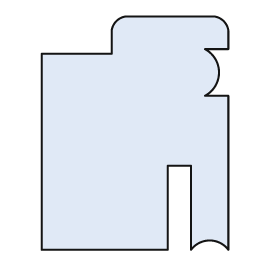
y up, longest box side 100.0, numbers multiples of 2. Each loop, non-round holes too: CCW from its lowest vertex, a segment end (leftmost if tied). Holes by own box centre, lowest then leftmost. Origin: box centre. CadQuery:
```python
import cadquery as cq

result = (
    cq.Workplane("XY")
    .moveTo(-40.0, -50.0)
    .lineTo(14.0, -50.0)
    .lineTo(14.0, -14.0)
    .lineTo(24.0, -14.0)
    .lineTo(24.0, -50.0)
    .threePointArc((32.0, -46.0), (40.0, -50.0))
    .lineTo(40.0, 16.0)
    .lineTo(30.0, 16.0)
    .threePointArc((36.0, 26.0), (30.0, 36.0))
    .lineTo(40.0, 36.0)
    .lineTo(40.0, 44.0)
    .threePointArc((38.0, 48.0), (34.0, 50.0))
    .lineTo(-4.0, 50.0)
    .threePointArc((-8.0, 48.0), (-10.0, 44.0))
    .lineTo(-10.0, 34.0)
    .lineTo(-40.0, 34.0)
    .close()
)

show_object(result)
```